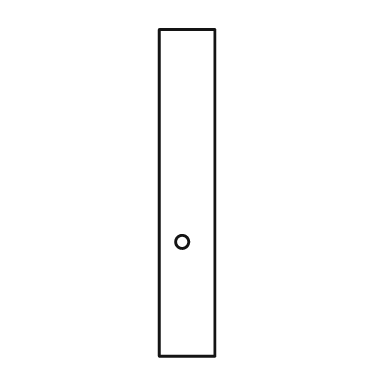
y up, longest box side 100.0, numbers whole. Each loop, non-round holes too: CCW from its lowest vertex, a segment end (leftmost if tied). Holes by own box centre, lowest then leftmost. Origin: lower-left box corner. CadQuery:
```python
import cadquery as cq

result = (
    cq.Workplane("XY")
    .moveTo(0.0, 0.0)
    .lineTo(17.0, 0.0)
    .lineTo(17.0, 100.0)
    .lineTo(0.0, 100.0)
    .close()
    .moveTo(7.0, 35.0)
    .circle(2.0)
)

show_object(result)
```